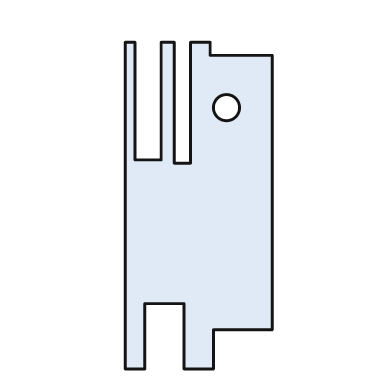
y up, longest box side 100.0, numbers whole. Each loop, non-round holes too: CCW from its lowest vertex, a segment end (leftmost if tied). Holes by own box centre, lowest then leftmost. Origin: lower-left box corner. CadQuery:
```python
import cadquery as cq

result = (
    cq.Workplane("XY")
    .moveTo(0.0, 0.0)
    .lineTo(6.0, 0.0)
    .lineTo(6.0, 20.0)
    .lineTo(18.0, 20.0)
    .lineTo(18.0, 0.0)
    .lineTo(27.0, 0.0)
    .lineTo(27.0, 12.0)
    .lineTo(45.0, 12.0)
    .lineTo(45.0, 96.0)
    .lineTo(26.0, 96.0)
    .lineTo(26.0, 100.0)
    .lineTo(20.0, 100.0)
    .lineTo(20.0, 63.0)
    .lineTo(15.0, 63.0)
    .lineTo(15.0, 100.0)
    .lineTo(11.0, 100.0)
    .lineTo(11.0, 64.0)
    .lineTo(3.0, 64.0)
    .lineTo(3.0, 100.0)
    .lineTo(0.0, 100.0)
    .close()
    .moveTo(31.0, 80.0)
    .circle(4.0)
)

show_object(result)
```